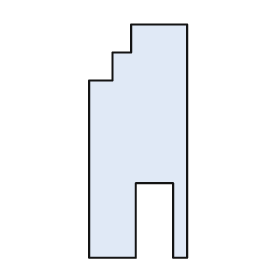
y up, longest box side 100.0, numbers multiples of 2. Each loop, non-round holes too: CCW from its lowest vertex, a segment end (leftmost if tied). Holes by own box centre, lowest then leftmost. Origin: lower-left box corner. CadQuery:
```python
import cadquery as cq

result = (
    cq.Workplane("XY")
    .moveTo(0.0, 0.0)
    .lineTo(20.0, 0.0)
    .lineTo(20.0, 32.0)
    .lineTo(36.0, 32.0)
    .lineTo(36.0, 0.0)
    .lineTo(42.0, 0.0)
    .lineTo(42.0, 100.0)
    .lineTo(18.0, 100.0)
    .lineTo(18.0, 88.0)
    .lineTo(10.0, 88.0)
    .lineTo(10.0, 76.0)
    .lineTo(0.0, 76.0)
    .close()
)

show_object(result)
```